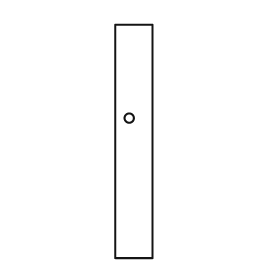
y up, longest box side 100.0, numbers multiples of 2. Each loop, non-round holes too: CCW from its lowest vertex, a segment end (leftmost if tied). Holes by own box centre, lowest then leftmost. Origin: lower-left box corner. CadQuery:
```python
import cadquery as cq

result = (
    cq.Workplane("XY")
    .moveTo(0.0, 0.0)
    .lineTo(16.0, 0.0)
    .lineTo(16.0, 100.0)
    .lineTo(0.0, 100.0)
    .close()
    .moveTo(6.0, 60.0)
    .circle(2.0)
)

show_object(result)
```